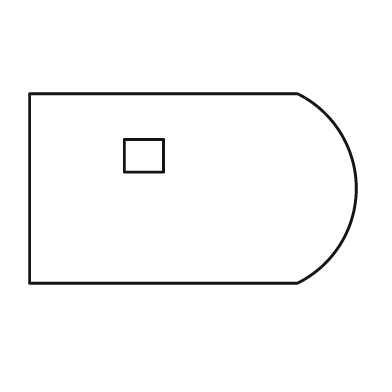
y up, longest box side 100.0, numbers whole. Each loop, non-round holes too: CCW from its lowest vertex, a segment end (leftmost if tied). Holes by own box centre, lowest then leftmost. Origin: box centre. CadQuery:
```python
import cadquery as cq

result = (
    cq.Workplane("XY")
    .moveTo(-50.0, -29.0)
    .lineTo(32.0, -29.0)
    .threePointArc((50.0, 0.0), (32.0, 29.0))
    .lineTo(-50.0, 29.0)
    .close()
    .moveTo(-21.0, 5.0)
    .lineTo(-9.0, 5.0)
    .lineTo(-9.0, 15.0)
    .lineTo(-21.0, 15.0)
    .close()
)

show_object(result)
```